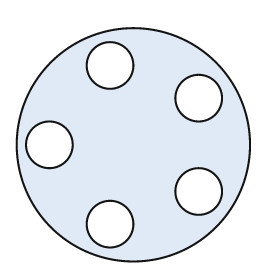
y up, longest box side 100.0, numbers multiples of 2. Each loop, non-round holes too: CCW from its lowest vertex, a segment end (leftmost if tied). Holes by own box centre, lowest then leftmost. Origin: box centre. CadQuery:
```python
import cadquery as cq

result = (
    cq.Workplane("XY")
    .moveTo(0.0, 0.0)
    .circle(50.0)
    .moveTo(-10.0, -34.0)
    .circle(10.0)
    .moveTo(28.0, -20.0)
    .circle(10.0)
    .moveTo(-36.0, 0.0)
    .circle(10.0)
    .moveTo(28.0, 20.0)
    .circle(10.0)
    .moveTo(-10.0, 34.0)
    .circle(10.0)
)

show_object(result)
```